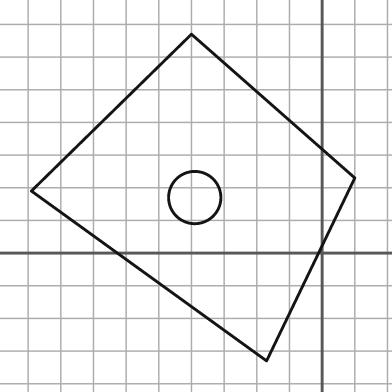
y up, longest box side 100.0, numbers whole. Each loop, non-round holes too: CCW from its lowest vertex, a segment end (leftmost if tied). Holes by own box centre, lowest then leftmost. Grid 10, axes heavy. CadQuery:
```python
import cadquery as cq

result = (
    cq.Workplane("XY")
    .moveTo(-17.0, -33.0)
    .lineTo(10.0, 23.0)
    .lineTo(-40.0, 67.0)
    .lineTo(-89.0, 19.0)
    .close()
    .moveTo(-39.0, 17.0)
    .circle(8.0)
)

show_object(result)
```